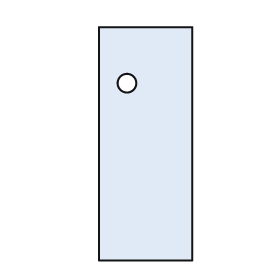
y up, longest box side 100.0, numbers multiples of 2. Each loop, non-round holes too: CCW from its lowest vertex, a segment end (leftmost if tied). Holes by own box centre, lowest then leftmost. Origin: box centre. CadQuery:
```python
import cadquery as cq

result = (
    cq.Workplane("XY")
    .moveTo(-20.0, -50.0)
    .lineTo(20.0, -50.0)
    .lineTo(20.0, 50.0)
    .lineTo(-20.0, 50.0)
    .close()
    .moveTo(-8.0, 26.0)
    .circle(4.0)
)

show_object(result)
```